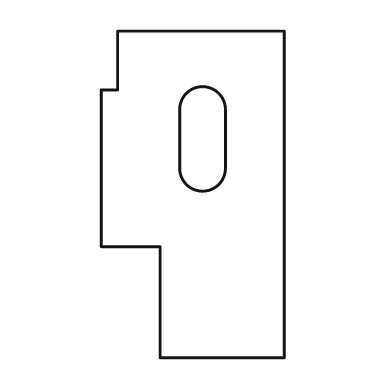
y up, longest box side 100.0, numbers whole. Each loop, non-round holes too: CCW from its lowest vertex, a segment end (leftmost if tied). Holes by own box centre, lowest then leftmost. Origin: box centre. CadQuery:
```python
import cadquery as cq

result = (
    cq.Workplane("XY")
    .moveTo(-10.0, -50.0)
    .lineTo(28.0, -50.0)
    .lineTo(28.0, 50.0)
    .lineTo(-23.0, 50.0)
    .lineTo(-23.0, 32.0)
    .lineTo(-28.0, 32.0)
    .lineTo(-28.0, -16.0)
    .lineTo(-10.0, -16.0)
    .close()
    .moveTo(-4.0, 8.0)
    .threePointArc((3.0, 1.0), (10.0, 8.0))
    .lineTo(10.0, 26.0)
    .threePointArc((3.0, 33.0), (-4.0, 26.0))
    .close()
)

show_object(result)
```